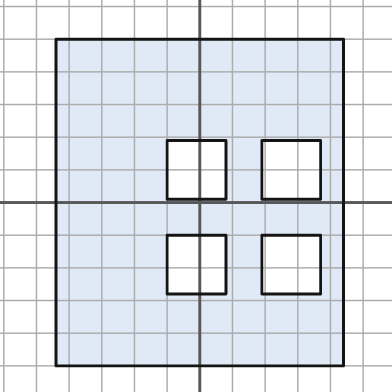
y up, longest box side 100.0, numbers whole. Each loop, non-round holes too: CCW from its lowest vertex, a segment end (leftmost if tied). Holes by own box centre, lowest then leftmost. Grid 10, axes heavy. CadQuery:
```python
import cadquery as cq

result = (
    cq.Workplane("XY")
    .moveTo(-44.0, -50.0)
    .lineTo(44.0, -50.0)
    .lineTo(44.0, 50.0)
    .lineTo(-44.0, 50.0)
    .close()
    .moveTo(-10.0, -28.0)
    .lineTo(8.0, -28.0)
    .lineTo(8.0, -10.0)
    .lineTo(-10.0, -10.0)
    .close()
    .moveTo(19.0, -28.0)
    .lineTo(37.0, -28.0)
    .lineTo(37.0, -10.0)
    .lineTo(19.0, -10.0)
    .close()
    .moveTo(-10.0, 1.0)
    .lineTo(8.0, 1.0)
    .lineTo(8.0, 19.0)
    .lineTo(-10.0, 19.0)
    .close()
    .moveTo(19.0, 1.0)
    .lineTo(37.0, 1.0)
    .lineTo(37.0, 19.0)
    .lineTo(19.0, 19.0)
    .close()
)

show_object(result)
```